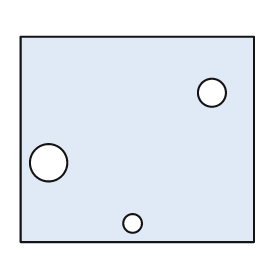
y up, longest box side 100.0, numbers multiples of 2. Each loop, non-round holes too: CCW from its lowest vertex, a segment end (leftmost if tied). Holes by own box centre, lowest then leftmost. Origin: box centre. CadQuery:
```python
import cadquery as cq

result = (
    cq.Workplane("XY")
    .moveTo(-50.0, -44.0)
    .lineTo(50.0, -44.0)
    .lineTo(50.0, 44.0)
    .lineTo(-50.0, 44.0)
    .close()
    .moveTo(-2.0, -36.0)
    .circle(4.0)
    .moveTo(-38.0, -10.0)
    .circle(8.0)
    .moveTo(32.0, 20.0)
    .circle(6.0)
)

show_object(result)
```